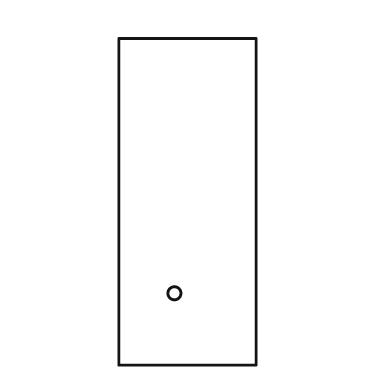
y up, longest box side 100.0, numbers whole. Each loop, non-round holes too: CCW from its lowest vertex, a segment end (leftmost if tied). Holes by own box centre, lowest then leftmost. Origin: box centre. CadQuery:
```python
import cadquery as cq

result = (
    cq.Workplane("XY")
    .moveTo(-21.0, -50.0)
    .lineTo(21.0, -50.0)
    .lineTo(21.0, 50.0)
    .lineTo(-21.0, 50.0)
    .close()
    .moveTo(-4.0, -28.0)
    .circle(2.0)
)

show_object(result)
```